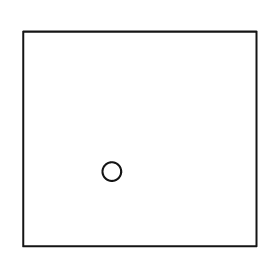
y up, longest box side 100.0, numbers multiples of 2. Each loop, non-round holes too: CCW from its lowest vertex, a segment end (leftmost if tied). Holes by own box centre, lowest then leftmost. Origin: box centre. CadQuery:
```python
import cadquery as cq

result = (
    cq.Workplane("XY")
    .moveTo(-50.0, -46.0)
    .lineTo(50.0, -46.0)
    .lineTo(50.0, 46.0)
    .lineTo(-50.0, 46.0)
    .close()
    .moveTo(-12.0, -14.0)
    .circle(4.0)
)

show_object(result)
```